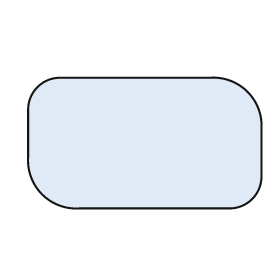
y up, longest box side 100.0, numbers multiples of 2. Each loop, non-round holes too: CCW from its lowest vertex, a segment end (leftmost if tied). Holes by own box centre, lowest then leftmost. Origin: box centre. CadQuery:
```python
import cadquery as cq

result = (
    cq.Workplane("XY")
    .moveTo(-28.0, -28.0)
    .lineTo(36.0, -28.0)
    .threePointArc((46.0, -24.0), (50.0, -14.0))
    .lineTo(50.0, 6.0)
    .threePointArc((44.0, 22.0), (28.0, 28.0))
    .lineTo(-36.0, 28.0)
    .threePointArc((-46.0, 24.0), (-50.0, 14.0))
    .lineTo(-50.0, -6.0)
    .threePointArc((-44.0, -22.0), (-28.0, -28.0))
    .close()
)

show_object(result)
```